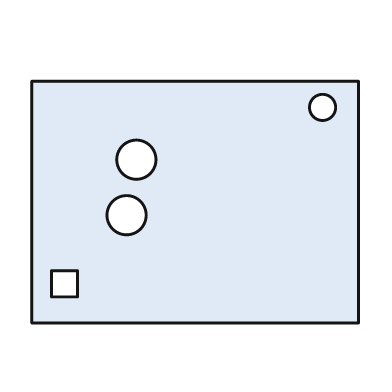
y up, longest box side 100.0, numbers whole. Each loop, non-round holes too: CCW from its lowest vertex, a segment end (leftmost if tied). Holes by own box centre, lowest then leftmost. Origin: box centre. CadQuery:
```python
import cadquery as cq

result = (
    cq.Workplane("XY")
    .moveTo(-50.0, -37.0)
    .lineTo(50.0, -37.0)
    .lineTo(50.0, 37.0)
    .lineTo(-50.0, 37.0)
    .close()
    .moveTo(-44.0, -29.0)
    .lineTo(-36.0, -29.0)
    .lineTo(-36.0, -21.0)
    .lineTo(-44.0, -21.0)
    .close()
    .moveTo(-21.0, -4.0)
    .circle(6.0)
    .moveTo(-18.0, 13.0)
    .circle(6.0)
    .moveTo(39.0, 29.0)
    .circle(4.0)
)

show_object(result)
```